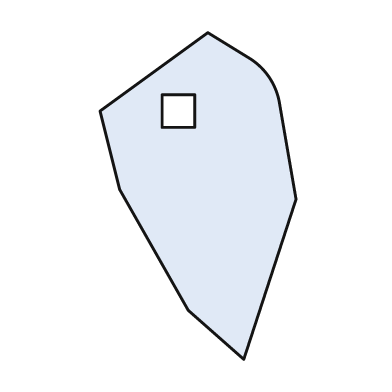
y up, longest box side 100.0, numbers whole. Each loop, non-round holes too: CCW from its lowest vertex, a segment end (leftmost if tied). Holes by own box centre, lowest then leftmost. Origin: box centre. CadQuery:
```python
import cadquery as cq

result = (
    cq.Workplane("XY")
    .moveTo(14.0, -50.0)
    .lineTo(30.0, -1.0)
    .lineTo(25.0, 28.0)
    .threePointArc((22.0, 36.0), (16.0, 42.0))
    .lineTo(3.0, 50.0)
    .lineTo(-30.0, 26.0)
    .lineTo(-24.0, 2.0)
    .lineTo(-3.0, -35.0)
    .close()
    .moveTo(-11.0, 21.0)
    .lineTo(-1.0, 21.0)
    .lineTo(-1.0, 31.0)
    .lineTo(-11.0, 31.0)
    .close()
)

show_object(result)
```